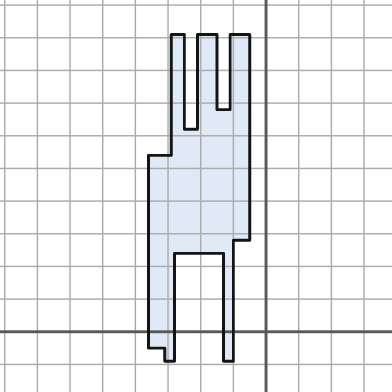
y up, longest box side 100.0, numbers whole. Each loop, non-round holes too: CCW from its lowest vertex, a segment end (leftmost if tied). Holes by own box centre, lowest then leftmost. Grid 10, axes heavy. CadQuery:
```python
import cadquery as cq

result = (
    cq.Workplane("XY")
    .moveTo(-31.0, -9.0)
    .lineTo(-28.0, -9.0)
    .lineTo(-28.0, 24.0)
    .lineTo(-13.0, 24.0)
    .lineTo(-13.0, -9.0)
    .lineTo(-10.0, -9.0)
    .lineTo(-10.0, 28.0)
    .lineTo(-5.0, 28.0)
    .lineTo(-5.0, 91.0)
    .lineTo(-11.0, 91.0)
    .lineTo(-11.0, 68.0)
    .lineTo(-15.0, 68.0)
    .lineTo(-15.0, 91.0)
    .lineTo(-21.0, 91.0)
    .lineTo(-21.0, 62.0)
    .lineTo(-25.0, 62.0)
    .lineTo(-25.0, 91.0)
    .lineTo(-29.0, 91.0)
    .lineTo(-29.0, 54.0)
    .lineTo(-36.0, 54.0)
    .lineTo(-36.0, -5.0)
    .lineTo(-31.0, -5.0)
    .close()
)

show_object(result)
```